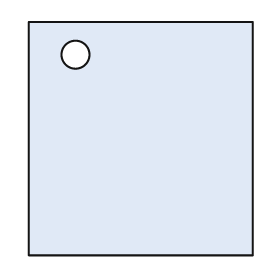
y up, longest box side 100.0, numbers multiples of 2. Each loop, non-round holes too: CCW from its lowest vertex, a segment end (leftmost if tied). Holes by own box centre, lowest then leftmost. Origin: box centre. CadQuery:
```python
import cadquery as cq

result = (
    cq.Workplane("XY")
    .moveTo(-48.0, -50.0)
    .lineTo(48.0, -50.0)
    .lineTo(48.0, 50.0)
    .lineTo(-48.0, 50.0)
    .close()
    .moveTo(-28.0, 36.0)
    .circle(6.0)
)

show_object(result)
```